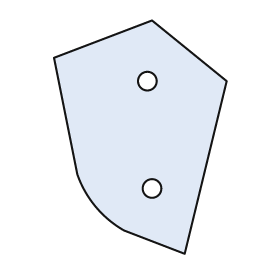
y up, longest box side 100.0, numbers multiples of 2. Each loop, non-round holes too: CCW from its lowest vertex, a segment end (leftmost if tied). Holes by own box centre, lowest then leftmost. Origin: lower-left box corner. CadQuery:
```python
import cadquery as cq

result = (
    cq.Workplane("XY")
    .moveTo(56.0, 0.0)
    .lineTo(74.0, 74.0)
    .lineTo(42.0, 100.0)
    .lineTo(0.0, 84.0)
    .lineTo(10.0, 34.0)
    .threePointArc((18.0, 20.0), (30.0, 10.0))
    .close()
    .moveTo(42.0, 28.0)
    .circle(4.0)
    .moveTo(40.0, 74.0)
    .circle(4.0)
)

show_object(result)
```